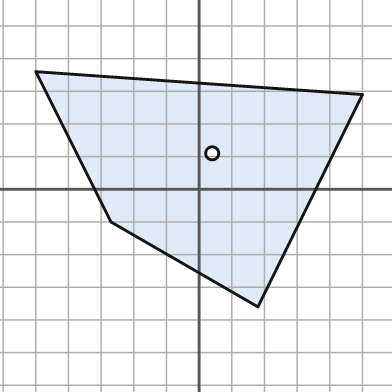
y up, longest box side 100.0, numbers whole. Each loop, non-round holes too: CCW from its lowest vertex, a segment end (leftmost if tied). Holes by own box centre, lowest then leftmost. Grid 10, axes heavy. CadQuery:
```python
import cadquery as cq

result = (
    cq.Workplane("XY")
    .moveTo(18.0, -36.0)
    .lineTo(50.0, 29.0)
    .lineTo(-50.0, 36.0)
    .lineTo(-27.0, -10.0)
    .close()
    .moveTo(4.0, 11.0)
    .circle(2.0)
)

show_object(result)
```